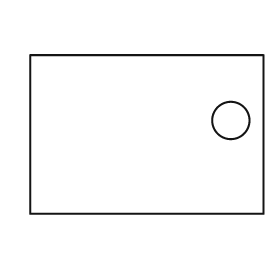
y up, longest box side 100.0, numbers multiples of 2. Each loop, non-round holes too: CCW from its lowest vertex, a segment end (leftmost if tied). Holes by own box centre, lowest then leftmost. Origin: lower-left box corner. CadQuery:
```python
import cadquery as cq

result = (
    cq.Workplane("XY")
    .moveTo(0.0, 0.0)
    .lineTo(100.0, 0.0)
    .lineTo(100.0, 68.0)
    .lineTo(0.0, 68.0)
    .close()
    .moveTo(86.0, 40.0)
    .circle(8.0)
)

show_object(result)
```